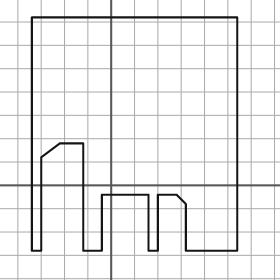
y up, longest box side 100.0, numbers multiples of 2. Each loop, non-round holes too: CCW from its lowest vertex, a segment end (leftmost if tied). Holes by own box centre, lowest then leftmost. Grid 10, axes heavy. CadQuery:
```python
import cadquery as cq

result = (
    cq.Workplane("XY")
    .moveTo(-34.0, -28.0)
    .lineTo(-30.0, -28.0)
    .lineTo(-30.0, 12.0)
    .lineTo(-22.0, 18.0)
    .lineTo(-12.0, 18.0)
    .lineTo(-12.0, -28.0)
    .lineTo(-4.0, -28.0)
    .lineTo(-4.0, -4.0)
    .lineTo(16.0, -4.0)
    .lineTo(16.0, -28.0)
    .lineTo(20.0, -28.0)
    .lineTo(20.0, -4.0)
    .lineTo(28.0, -4.0)
    .lineTo(32.0, -8.0)
    .lineTo(32.0, -28.0)
    .lineTo(54.0, -28.0)
    .lineTo(54.0, 72.0)
    .lineTo(-34.0, 72.0)
    .close()
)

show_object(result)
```